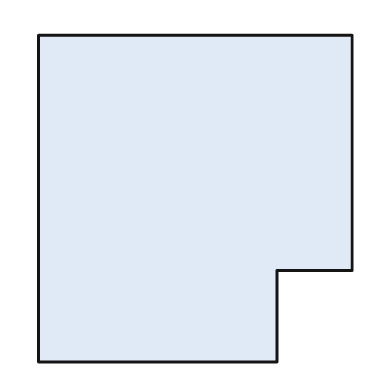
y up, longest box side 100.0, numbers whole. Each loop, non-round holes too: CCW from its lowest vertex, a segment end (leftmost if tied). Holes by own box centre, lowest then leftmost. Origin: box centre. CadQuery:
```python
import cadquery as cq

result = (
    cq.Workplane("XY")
    .moveTo(-48.0, -50.0)
    .lineTo(25.0, -50.0)
    .lineTo(25.0, -22.0)
    .lineTo(48.0, -22.0)
    .lineTo(48.0, 50.0)
    .lineTo(-48.0, 50.0)
    .close()
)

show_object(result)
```